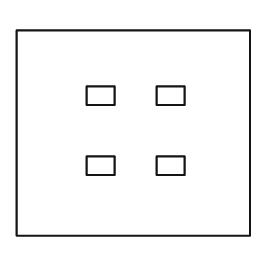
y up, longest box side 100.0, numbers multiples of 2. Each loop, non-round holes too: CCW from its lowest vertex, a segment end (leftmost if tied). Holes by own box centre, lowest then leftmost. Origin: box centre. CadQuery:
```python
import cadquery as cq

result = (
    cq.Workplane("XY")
    .moveTo(-50.0, -44.0)
    .lineTo(50.0, -44.0)
    .lineTo(50.0, 44.0)
    .lineTo(-50.0, 44.0)
    .close()
    .moveTo(-20.0, -18.0)
    .lineTo(-8.0, -18.0)
    .lineTo(-8.0, -10.0)
    .lineTo(-20.0, -10.0)
    .close()
    .moveTo(10.0, -18.0)
    .lineTo(22.0, -18.0)
    .lineTo(22.0, -10.0)
    .lineTo(10.0, -10.0)
    .close()
    .moveTo(-20.0, 12.0)
    .lineTo(-8.0, 12.0)
    .lineTo(-8.0, 20.0)
    .lineTo(-20.0, 20.0)
    .close()
    .moveTo(10.0, 12.0)
    .lineTo(22.0, 12.0)
    .lineTo(22.0, 20.0)
    .lineTo(10.0, 20.0)
    .close()
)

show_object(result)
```